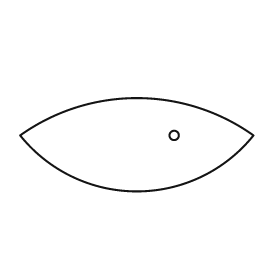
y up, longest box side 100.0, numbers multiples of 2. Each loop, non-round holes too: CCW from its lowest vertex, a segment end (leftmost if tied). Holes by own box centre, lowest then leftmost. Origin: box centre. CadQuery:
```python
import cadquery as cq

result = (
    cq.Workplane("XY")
    .moveTo(-50.0, 4.0)
    .threePointArc((0.0, -20.0), (50.0, 4.0))
    .threePointArc((0.0, 20.0), (-50.0, 4.0))
    .close()
    .moveTo(16.0, 4.0)
    .circle(2.0)
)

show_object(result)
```